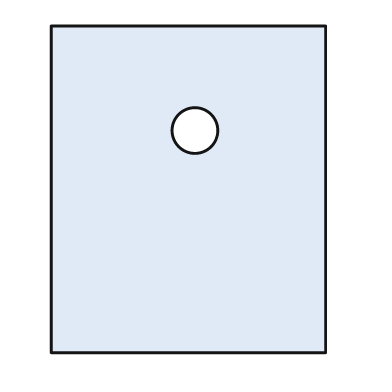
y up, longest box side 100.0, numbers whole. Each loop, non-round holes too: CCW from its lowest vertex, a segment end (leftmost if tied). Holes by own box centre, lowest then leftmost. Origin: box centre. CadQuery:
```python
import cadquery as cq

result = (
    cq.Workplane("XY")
    .moveTo(-42.0, -50.0)
    .lineTo(42.0, -50.0)
    .lineTo(42.0, 50.0)
    .lineTo(-42.0, 50.0)
    .close()
    .moveTo(2.0, 18.0)
    .circle(7.0)
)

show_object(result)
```